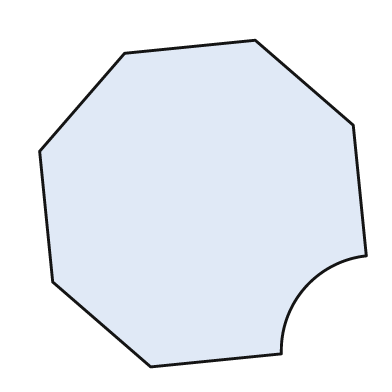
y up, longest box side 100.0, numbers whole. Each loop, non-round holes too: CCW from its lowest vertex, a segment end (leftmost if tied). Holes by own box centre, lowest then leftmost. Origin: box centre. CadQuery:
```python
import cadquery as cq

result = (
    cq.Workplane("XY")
    .moveTo(-16.0, -50.0)
    .lineTo(24.0, -46.0)
    .threePointArc((31.0, -26.0), (50.0, -16.0))
    .lineTo(46.0, 24.0)
    .lineTo(16.0, 50.0)
    .lineTo(-24.0, 46.0)
    .lineTo(-50.0, 16.0)
    .lineTo(-46.0, -24.0)
    .close()
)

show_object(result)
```